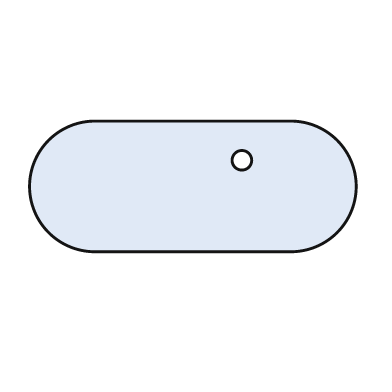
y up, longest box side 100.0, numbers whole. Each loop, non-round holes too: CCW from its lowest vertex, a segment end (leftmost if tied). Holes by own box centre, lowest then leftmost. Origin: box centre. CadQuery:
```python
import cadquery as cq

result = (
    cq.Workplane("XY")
    .moveTo(-30.0, -20.0)
    .lineTo(30.0, -20.0)
    .threePointArc((50.0, 0.0), (30.0, 20.0))
    .lineTo(-30.0, 20.0)
    .threePointArc((-50.0, 0.0), (-30.0, -20.0))
    .close()
    .moveTo(15.0, 8.0)
    .circle(3.0)
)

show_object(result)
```